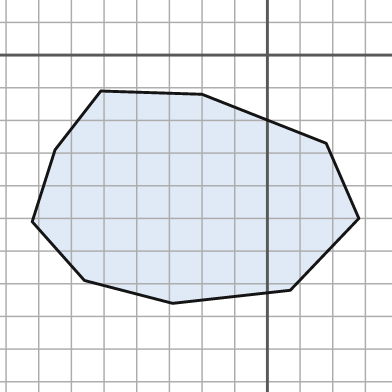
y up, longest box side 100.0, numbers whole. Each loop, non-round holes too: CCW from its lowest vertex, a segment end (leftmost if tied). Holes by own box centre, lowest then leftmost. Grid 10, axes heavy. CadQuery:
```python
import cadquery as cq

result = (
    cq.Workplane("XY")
    .moveTo(-29.0, -76.0)
    .lineTo(7.0, -72.0)
    .lineTo(28.0, -50.0)
    .lineTo(18.0, -27.0)
    .lineTo(-20.0, -12.0)
    .lineTo(-51.0, -11.0)
    .lineTo(-65.0, -29.0)
    .lineTo(-72.0, -51.0)
    .lineTo(-56.0, -69.0)
    .close()
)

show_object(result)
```